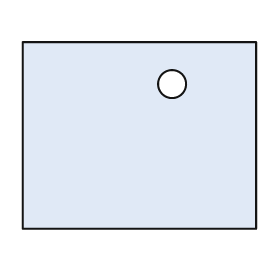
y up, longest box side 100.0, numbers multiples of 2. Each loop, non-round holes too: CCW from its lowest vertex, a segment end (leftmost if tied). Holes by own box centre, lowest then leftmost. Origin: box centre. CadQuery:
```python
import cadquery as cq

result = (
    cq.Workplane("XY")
    .moveTo(-50.0, -40.0)
    .lineTo(50.0, -40.0)
    .lineTo(50.0, 40.0)
    .lineTo(-50.0, 40.0)
    .close()
    .moveTo(14.0, 22.0)
    .circle(6.0)
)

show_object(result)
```